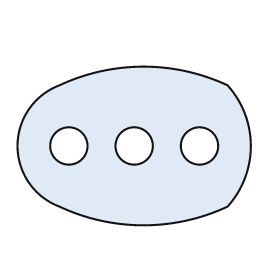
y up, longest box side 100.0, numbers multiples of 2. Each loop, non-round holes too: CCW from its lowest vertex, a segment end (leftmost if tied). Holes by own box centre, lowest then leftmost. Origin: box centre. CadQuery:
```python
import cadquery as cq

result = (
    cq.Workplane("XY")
    .moveTo(-32.0, -26.0)
    .threePointArc((4.0, -34.0), (40.0, -26.0))
    .threePointArc((50.0, 0.0), (40.0, 26.0))
    .threePointArc((4.0, 34.0), (-32.0, 26.0))
    .threePointArc((-50.0, 0.0), (-32.0, -26.0))
    .close()
    .moveTo(-28.0, 0.0)
    .circle(8.0)
    .moveTo(0.0, 0.0)
    .circle(8.0)
    .moveTo(28.0, 0.0)
    .circle(8.0)
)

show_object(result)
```